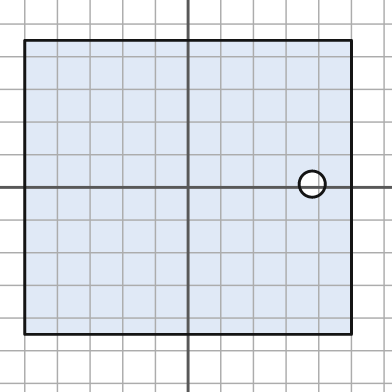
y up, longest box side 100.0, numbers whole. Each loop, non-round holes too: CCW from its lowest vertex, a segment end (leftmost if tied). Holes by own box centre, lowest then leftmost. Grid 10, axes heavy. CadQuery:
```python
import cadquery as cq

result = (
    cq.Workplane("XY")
    .moveTo(-50.0, -45.0)
    .lineTo(50.0, -45.0)
    .lineTo(50.0, 45.0)
    .lineTo(-50.0, 45.0)
    .close()
    .moveTo(38.0, 1.0)
    .circle(4.0)
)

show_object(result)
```